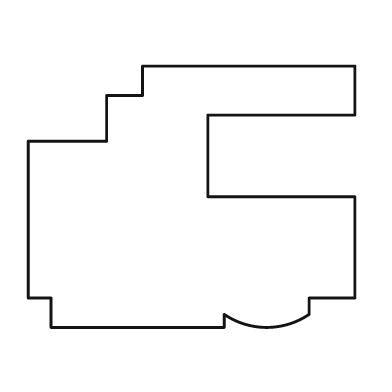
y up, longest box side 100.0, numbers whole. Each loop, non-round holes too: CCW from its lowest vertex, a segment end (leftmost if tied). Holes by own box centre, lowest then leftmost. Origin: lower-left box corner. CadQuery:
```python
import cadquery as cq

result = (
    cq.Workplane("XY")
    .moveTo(7.0, 0.0)
    .lineTo(60.0, 0.0)
    .lineTo(60.0, 4.0)
    .threePointArc((73.0, 0.0), (86.0, 4.0))
    .lineTo(86.0, 9.0)
    .lineTo(100.0, 9.0)
    .lineTo(100.0, 40.0)
    .lineTo(55.0, 40.0)
    .lineTo(55.0, 65.0)
    .lineTo(100.0, 65.0)
    .lineTo(100.0, 80.0)
    .lineTo(35.0, 80.0)
    .lineTo(35.0, 71.0)
    .lineTo(24.0, 71.0)
    .lineTo(24.0, 57.0)
    .lineTo(0.0, 57.0)
    .lineTo(0.0, 9.0)
    .lineTo(7.0, 9.0)
    .close()
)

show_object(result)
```